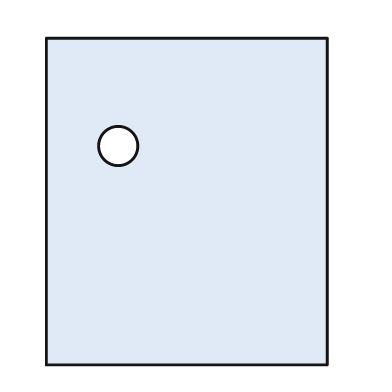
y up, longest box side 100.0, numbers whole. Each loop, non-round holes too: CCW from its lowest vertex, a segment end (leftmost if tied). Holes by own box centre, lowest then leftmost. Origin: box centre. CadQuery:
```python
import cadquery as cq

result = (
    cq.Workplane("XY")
    .moveTo(-43.0, -50.0)
    .lineTo(43.0, -50.0)
    .lineTo(43.0, 50.0)
    .lineTo(-43.0, 50.0)
    .close()
    .moveTo(-21.0, 17.0)
    .circle(6.0)
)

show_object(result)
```